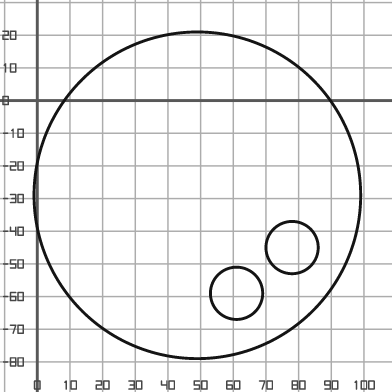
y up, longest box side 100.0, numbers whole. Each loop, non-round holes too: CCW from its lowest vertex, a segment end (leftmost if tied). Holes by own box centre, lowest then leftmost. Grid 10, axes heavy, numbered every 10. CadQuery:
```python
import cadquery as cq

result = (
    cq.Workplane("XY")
    .moveTo(49.0, -29.0)
    .circle(50.0)
    .moveTo(61.0, -59.0)
    .circle(8.0)
    .moveTo(78.0, -45.0)
    .circle(8.0)
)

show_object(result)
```